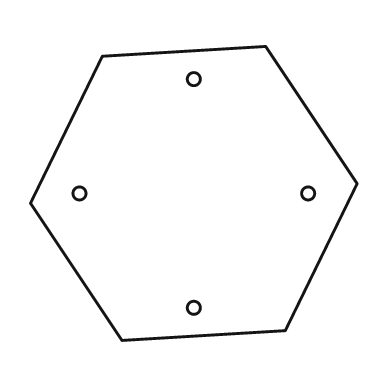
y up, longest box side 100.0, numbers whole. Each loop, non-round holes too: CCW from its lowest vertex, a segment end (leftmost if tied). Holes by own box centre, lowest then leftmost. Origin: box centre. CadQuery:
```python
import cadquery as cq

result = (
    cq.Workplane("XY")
    .moveTo(-22.0, -45.0)
    .lineTo(28.0, -42.0)
    .lineTo(50.0, 3.0)
    .lineTo(22.0, 45.0)
    .lineTo(-28.0, 42.0)
    .lineTo(-50.0, -3.0)
    .close()
    .moveTo(0.0, -35.0)
    .circle(2.0)
    .moveTo(-35.0, 0.0)
    .circle(2.0)
    .moveTo(35.0, 0.0)
    .circle(2.0)
    .moveTo(0.0, 35.0)
    .circle(2.0)
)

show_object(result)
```